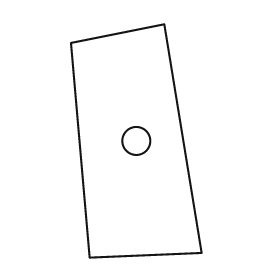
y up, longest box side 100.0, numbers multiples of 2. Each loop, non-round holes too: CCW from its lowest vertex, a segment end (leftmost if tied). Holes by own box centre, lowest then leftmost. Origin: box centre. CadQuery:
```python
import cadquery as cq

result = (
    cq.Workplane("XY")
    .moveTo(-20.0, -50.0)
    .lineTo(28.0, -48.0)
    .lineTo(12.0, 50.0)
    .lineTo(-28.0, 42.0)
    .close()
    .moveTo(0.0, 0.0)
    .circle(6.0)
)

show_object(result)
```